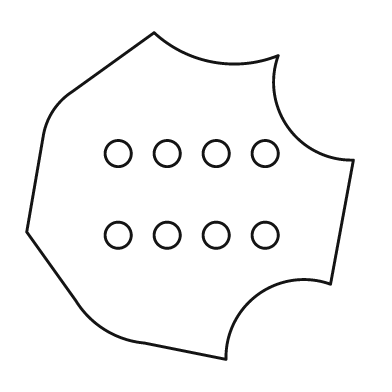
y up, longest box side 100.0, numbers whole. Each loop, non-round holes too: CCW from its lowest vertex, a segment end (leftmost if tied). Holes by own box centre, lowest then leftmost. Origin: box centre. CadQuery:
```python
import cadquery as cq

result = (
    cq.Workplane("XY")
    .moveTo(11.0, -50.0)
    .threePointArc((21.0, -30.0), (43.0, -27.0))
    .lineTo(50.0, 11.0)
    .threePointArc((30.0, 21.0), (27.0, 43.0))
    .threePointArc((7.0, 41.0), (-11.0, 50.0))
    .lineTo(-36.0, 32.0)
    .threePointArc((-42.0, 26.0), (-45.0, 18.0))
    .lineTo(-50.0, -11.0)
    .lineTo(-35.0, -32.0)
    .threePointArc((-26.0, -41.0), (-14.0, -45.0))
    .close()
    .moveTo(-22.0, -12.0)
    .circle(4.0)
    .moveTo(-7.0, -12.0)
    .circle(4.0)
    .moveTo(8.0, -12.0)
    .circle(4.0)
    .moveTo(23.0, -12.0)
    .circle(4.0)
    .moveTo(-22.0, 13.0)
    .circle(4.0)
    .moveTo(-7.0, 13.0)
    .circle(4.0)
    .moveTo(8.0, 13.0)
    .circle(4.0)
    .moveTo(23.0, 13.0)
    .circle(4.0)
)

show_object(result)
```